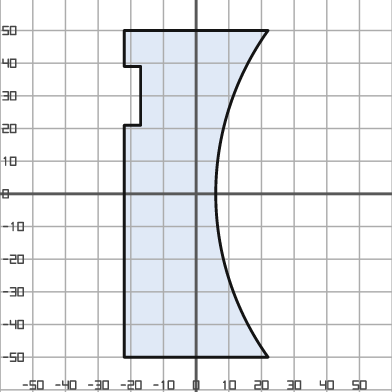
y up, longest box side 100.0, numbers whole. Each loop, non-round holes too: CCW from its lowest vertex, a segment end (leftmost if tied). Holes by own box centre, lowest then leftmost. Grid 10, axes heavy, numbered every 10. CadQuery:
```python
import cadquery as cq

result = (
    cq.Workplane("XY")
    .moveTo(-22.0, -50.0)
    .lineTo(22.0, -50.0)
    .threePointArc((6.0, 0.0), (22.0, 50.0))
    .lineTo(-22.0, 50.0)
    .lineTo(-22.0, 39.0)
    .lineTo(-17.0, 39.0)
    .lineTo(-17.0, 21.0)
    .lineTo(-22.0, 21.0)
    .close()
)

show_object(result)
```